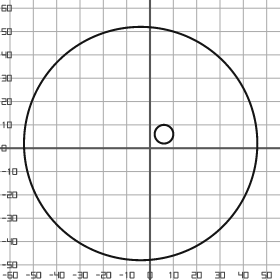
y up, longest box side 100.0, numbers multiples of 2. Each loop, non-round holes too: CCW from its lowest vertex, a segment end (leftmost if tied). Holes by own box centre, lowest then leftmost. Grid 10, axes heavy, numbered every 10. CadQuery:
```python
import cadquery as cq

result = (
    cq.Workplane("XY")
    .moveTo(-4.0, 2.0)
    .circle(50.0)
    .moveTo(6.0, 6.0)
    .circle(4.0)
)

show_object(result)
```